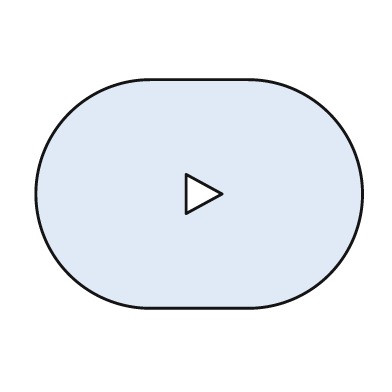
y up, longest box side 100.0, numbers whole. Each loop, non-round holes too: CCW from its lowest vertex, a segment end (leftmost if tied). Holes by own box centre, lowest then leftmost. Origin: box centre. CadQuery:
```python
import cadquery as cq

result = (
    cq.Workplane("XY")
    .moveTo(-15.0, -35.0)
    .lineTo(15.0, -35.0)
    .threePointArc((50.0, 0.0), (15.0, 35.0))
    .lineTo(-15.0, 35.0)
    .threePointArc((-50.0, 0.0), (-15.0, -35.0))
    .close()
    .moveTo(-4.0, -6.0)
    .lineTo(7.0, 0.0)
    .lineTo(-4.0, 6.0)
    .close()
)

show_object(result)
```